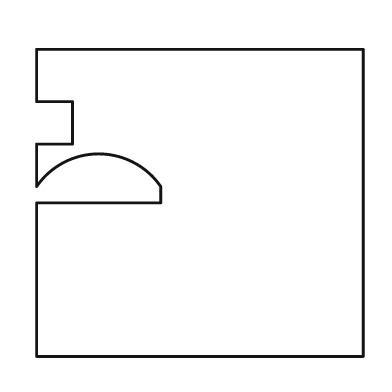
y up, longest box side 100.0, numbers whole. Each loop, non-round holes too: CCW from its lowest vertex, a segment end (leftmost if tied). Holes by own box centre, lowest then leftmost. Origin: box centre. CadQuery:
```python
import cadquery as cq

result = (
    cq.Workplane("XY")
    .moveTo(-50.0, -47.0)
    .lineTo(50.0, -47.0)
    .lineTo(50.0, 47.0)
    .lineTo(-50.0, 47.0)
    .lineTo(-50.0, 31.0)
    .lineTo(-39.0, 31.0)
    .lineTo(-39.0, 18.0)
    .lineTo(-50.0, 18.0)
    .lineTo(-50.0, 5.0)
    .threePointArc((-31.0, 15.0), (-12.0, 5.0))
    .lineTo(-12.0, 0.0)
    .lineTo(-50.0, 0.0)
    .close()
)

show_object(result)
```